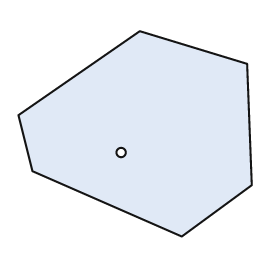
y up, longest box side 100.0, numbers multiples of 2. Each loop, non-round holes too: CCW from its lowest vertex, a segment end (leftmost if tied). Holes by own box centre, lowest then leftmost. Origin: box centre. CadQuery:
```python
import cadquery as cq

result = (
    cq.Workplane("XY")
    .moveTo(20.0, -44.0)
    .lineTo(50.0, -22.0)
    .lineTo(48.0, 30.0)
    .lineTo(2.0, 44.0)
    .lineTo(-50.0, 8.0)
    .lineTo(-44.0, -16.0)
    .close()
    .moveTo(-6.0, -8.0)
    .circle(2.0)
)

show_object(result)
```